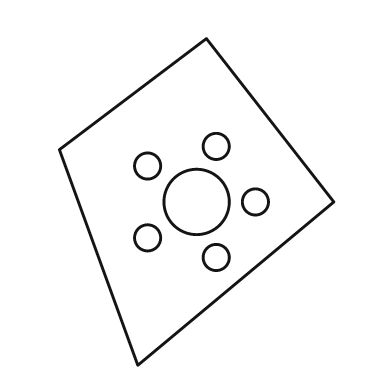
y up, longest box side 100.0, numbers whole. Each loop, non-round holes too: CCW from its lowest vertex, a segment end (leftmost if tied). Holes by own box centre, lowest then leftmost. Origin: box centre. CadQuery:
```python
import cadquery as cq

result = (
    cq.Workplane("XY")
    .moveTo(-18.0, -50.0)
    .lineTo(42.0, 0.0)
    .lineTo(3.0, 50.0)
    .lineTo(-42.0, 16.0)
    .close()
    .moveTo(6.0, -17.0)
    .circle(4.0)
    .moveTo(-15.0, -11.0)
    .circle(4.0)
    .moveTo(0.0, 0.0)
    .circle(10.0)
    .moveTo(18.0, 0.0)
    .circle(4.0)
    .moveTo(-15.0, 11.0)
    .circle(4.0)
    .moveTo(6.0, 17.0)
    .circle(4.0)
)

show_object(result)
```